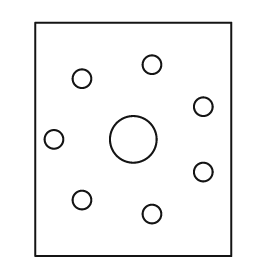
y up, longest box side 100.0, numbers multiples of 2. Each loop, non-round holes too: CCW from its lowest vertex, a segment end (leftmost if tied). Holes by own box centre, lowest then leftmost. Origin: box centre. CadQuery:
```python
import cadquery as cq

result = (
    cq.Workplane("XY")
    .moveTo(-42.0, -50.0)
    .lineTo(42.0, -50.0)
    .lineTo(42.0, 50.0)
    .lineTo(-42.0, 50.0)
    .close()
    .moveTo(8.0, -32.0)
    .circle(4.0)
    .moveTo(-22.0, -26.0)
    .circle(4.0)
    .moveTo(30.0, -14.0)
    .circle(4.0)
    .moveTo(-34.0, 0.0)
    .circle(4.0)
    .moveTo(0.0, 0.0)
    .circle(10.0)
    .moveTo(30.0, 14.0)
    .circle(4.0)
    .moveTo(-22.0, 26.0)
    .circle(4.0)
    .moveTo(8.0, 32.0)
    .circle(4.0)
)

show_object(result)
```